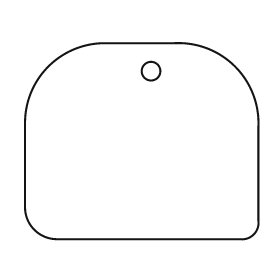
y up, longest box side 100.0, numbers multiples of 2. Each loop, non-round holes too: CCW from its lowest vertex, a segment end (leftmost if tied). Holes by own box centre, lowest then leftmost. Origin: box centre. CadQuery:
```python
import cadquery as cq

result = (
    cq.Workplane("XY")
    .moveTo(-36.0, -42.0)
    .lineTo(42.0, -42.0)
    .threePointArc((48.0, -40.0), (50.0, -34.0))
    .lineTo(50.0, 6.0)
    .threePointArc((40.0, 32.0), (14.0, 42.0))
    .lineTo(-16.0, 42.0)
    .threePointArc((-40.0, 32.0), (-50.0, 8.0))
    .lineTo(-50.0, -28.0)
    .threePointArc((-46.0, -38.0), (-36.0, -42.0))
    .close()
    .moveTo(4.0, 30.0)
    .circle(4.0)
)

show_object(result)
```